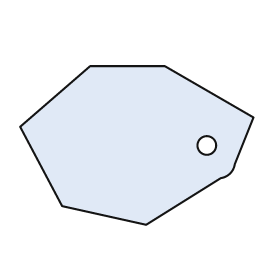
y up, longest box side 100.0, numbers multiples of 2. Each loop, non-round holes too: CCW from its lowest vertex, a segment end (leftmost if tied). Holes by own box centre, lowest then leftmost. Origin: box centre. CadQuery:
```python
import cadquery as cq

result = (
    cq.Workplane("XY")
    .moveTo(4.0, -34.0)
    .lineTo(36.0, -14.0)
    .threePointArc((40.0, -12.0), (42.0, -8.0))
    .lineTo(50.0, 12.0)
    .lineTo(12.0, 34.0)
    .lineTo(-20.0, 34.0)
    .lineTo(-50.0, 8.0)
    .lineTo(-32.0, -26.0)
    .close()
    .moveTo(30.0, 0.0)
    .circle(4.0)
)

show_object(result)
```